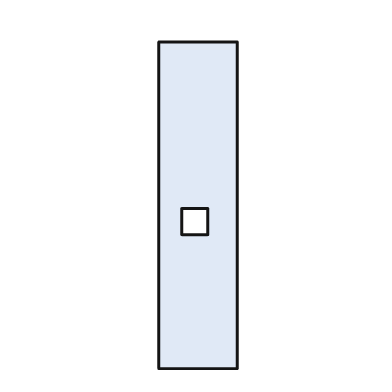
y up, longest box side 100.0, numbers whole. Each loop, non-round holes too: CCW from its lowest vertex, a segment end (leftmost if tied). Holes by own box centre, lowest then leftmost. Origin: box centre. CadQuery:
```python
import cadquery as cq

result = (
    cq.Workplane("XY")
    .moveTo(-12.0, -50.0)
    .lineTo(12.0, -50.0)
    .lineTo(12.0, 50.0)
    .lineTo(-12.0, 50.0)
    .close()
    .moveTo(-5.0, -9.0)
    .lineTo(3.0, -9.0)
    .lineTo(3.0, -1.0)
    .lineTo(-5.0, -1.0)
    .close()
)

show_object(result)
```